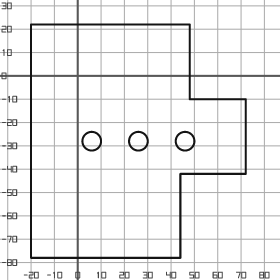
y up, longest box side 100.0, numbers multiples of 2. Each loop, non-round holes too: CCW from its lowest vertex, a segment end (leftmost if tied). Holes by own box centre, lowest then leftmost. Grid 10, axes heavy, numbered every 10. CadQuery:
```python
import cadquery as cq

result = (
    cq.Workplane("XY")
    .moveTo(-20.0, -78.0)
    .lineTo(44.0, -78.0)
    .lineTo(44.0, -42.0)
    .lineTo(72.0, -42.0)
    .lineTo(72.0, -10.0)
    .lineTo(48.0, -10.0)
    .lineTo(48.0, 22.0)
    .lineTo(-20.0, 22.0)
    .close()
    .moveTo(6.0, -28.0)
    .circle(4.0)
    .moveTo(26.0, -28.0)
    .circle(4.0)
    .moveTo(46.0, -28.0)
    .circle(4.0)
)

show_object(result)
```